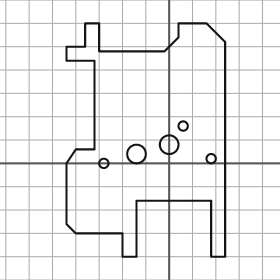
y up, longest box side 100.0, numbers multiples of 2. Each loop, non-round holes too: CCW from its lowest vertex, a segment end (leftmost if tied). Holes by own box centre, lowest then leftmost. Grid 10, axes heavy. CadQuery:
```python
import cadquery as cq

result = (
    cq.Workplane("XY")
    .moveTo(-20.0, -40.0)
    .lineTo(-14.0, -40.0)
    .lineTo(-14.0, -16.0)
    .lineTo(18.0, -16.0)
    .lineTo(18.0, -40.0)
    .lineTo(24.0, -40.0)
    .lineTo(24.0, 52.0)
    .lineTo(16.0, 60.0)
    .lineTo(4.0, 60.0)
    .lineTo(4.0, 54.0)
    .lineTo(-2.0, 48.0)
    .lineTo(-30.0, 48.0)
    .lineTo(-30.0, 60.0)
    .lineTo(-36.0, 60.0)
    .lineTo(-36.0, 50.0)
    .lineTo(-44.0, 50.0)
    .lineTo(-44.0, 44.0)
    .lineTo(-32.0, 44.0)
    .lineTo(-32.0, 6.0)
    .lineTo(-40.0, 6.0)
    .lineTo(-44.0, 0.0)
    .lineTo(-44.0, -26.0)
    .lineTo(-40.0, -30.0)
    .lineTo(-20.0, -30.0)
    .close()
    .moveTo(-28.0, 0.0)
    .circle(2.0)
    .moveTo(18.0, 2.0)
    .circle(2.0)
    .moveTo(-14.0, 4.0)
    .circle(4.0)
    .moveTo(0.0, 8.0)
    .circle(4.0)
    .moveTo(6.0, 16.0)
    .circle(2.0)
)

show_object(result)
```